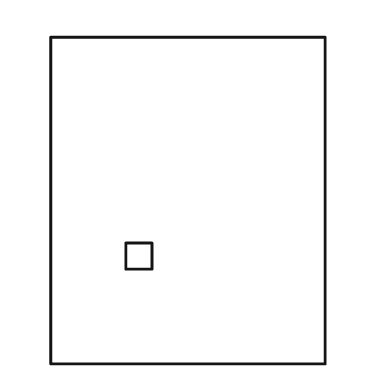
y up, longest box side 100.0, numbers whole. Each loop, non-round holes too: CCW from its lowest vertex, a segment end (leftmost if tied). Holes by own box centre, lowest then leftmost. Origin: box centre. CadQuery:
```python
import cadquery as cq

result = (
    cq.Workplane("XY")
    .moveTo(-42.0, -50.0)
    .lineTo(42.0, -50.0)
    .lineTo(42.0, 50.0)
    .lineTo(-42.0, 50.0)
    .close()
    .moveTo(-19.0, -21.0)
    .lineTo(-11.0, -21.0)
    .lineTo(-11.0, -13.0)
    .lineTo(-19.0, -13.0)
    .close()
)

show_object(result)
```